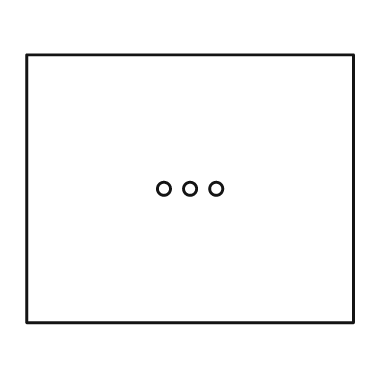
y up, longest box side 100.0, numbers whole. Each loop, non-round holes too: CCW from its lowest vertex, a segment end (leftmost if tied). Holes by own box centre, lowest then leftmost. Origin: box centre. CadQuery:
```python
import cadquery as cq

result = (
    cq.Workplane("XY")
    .moveTo(-50.0, -41.0)
    .lineTo(50.0, -41.0)
    .lineTo(50.0, 41.0)
    .lineTo(-50.0, 41.0)
    .close()
    .moveTo(-8.0, 0.0)
    .circle(2.0)
    .moveTo(0.0, 0.0)
    .circle(2.0)
    .moveTo(8.0, 0.0)
    .circle(2.0)
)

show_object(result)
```